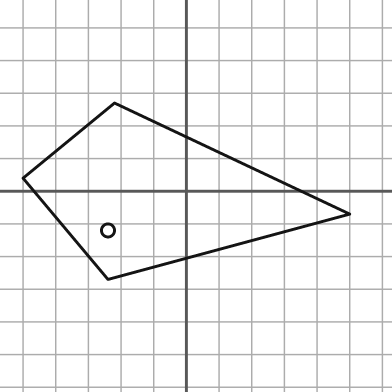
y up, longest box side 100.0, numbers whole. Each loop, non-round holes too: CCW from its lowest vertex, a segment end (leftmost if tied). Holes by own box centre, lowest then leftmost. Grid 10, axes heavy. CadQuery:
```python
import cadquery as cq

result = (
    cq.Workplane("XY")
    .moveTo(-24.0, -27.0)
    .lineTo(50.0, -7.0)
    .lineTo(-22.0, 27.0)
    .lineTo(-50.0, 4.0)
    .close()
    .moveTo(-24.0, -12.0)
    .circle(2.0)
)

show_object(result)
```